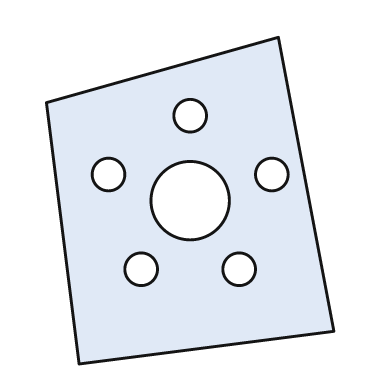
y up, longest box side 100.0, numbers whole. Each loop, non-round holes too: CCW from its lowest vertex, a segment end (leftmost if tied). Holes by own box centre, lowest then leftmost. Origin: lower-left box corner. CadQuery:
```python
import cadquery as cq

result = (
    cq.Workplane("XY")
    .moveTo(10.0, 0.0)
    .lineTo(88.0, 10.0)
    .lineTo(71.0, 100.0)
    .lineTo(0.0, 80.0)
    .close()
    .moveTo(29.0, 29.0)
    .circle(5.0)
    .moveTo(59.0, 29.0)
    .circle(5.0)
    .moveTo(44.0, 50.0)
    .circle(12.0)
    .moveTo(19.0, 58.0)
    .circle(5.0)
    .moveTo(69.0, 58.0)
    .circle(5.0)
    .moveTo(44.0, 76.0)
    .circle(5.0)
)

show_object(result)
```